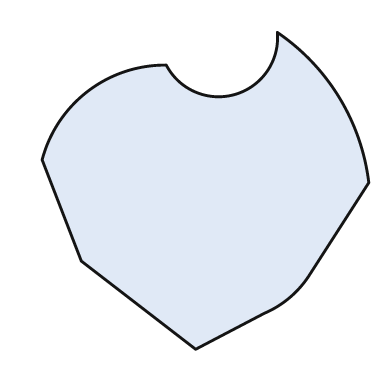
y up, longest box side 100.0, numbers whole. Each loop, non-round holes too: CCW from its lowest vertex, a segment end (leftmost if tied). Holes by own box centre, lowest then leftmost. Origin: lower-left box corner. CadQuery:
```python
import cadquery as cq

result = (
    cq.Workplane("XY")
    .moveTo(47.0, 0.0)
    .lineTo(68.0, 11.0)
    .threePointArc((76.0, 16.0), (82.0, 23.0))
    .lineTo(100.0, 51.0)
    .threePointArc((91.0, 77.0), (72.0, 97.0))
    .threePointArc((59.0, 78.0), (38.0, 87.0))
    .threePointArc((14.0, 79.0), (0.0, 58.0))
    .lineTo(12.0, 27.0)
    .close()
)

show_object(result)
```